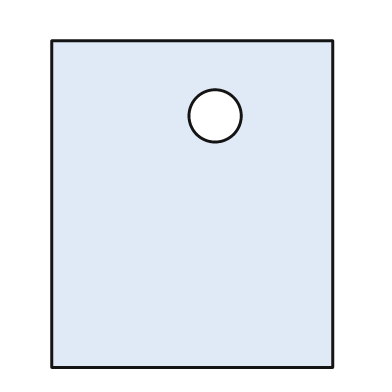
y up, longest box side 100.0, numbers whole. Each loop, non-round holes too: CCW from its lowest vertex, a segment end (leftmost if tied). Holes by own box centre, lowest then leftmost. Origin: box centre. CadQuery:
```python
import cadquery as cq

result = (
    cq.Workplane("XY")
    .moveTo(-43.0, -50.0)
    .lineTo(43.0, -50.0)
    .lineTo(43.0, 50.0)
    .lineTo(-43.0, 50.0)
    .close()
    .moveTo(7.0, 27.0)
    .circle(8.0)
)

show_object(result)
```